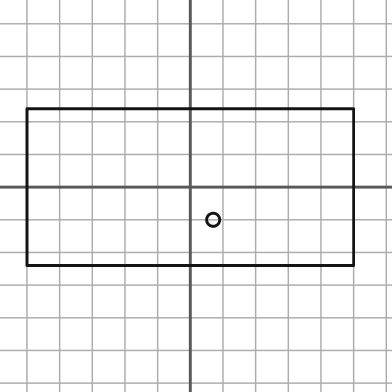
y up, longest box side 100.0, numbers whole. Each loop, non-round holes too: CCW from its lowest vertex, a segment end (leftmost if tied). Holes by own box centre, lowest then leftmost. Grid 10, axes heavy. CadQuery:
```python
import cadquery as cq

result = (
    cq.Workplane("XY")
    .moveTo(-50.0, -24.0)
    .lineTo(50.0, -24.0)
    .lineTo(50.0, 24.0)
    .lineTo(-50.0, 24.0)
    .close()
    .moveTo(7.0, -10.0)
    .circle(2.0)
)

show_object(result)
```